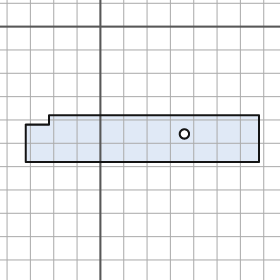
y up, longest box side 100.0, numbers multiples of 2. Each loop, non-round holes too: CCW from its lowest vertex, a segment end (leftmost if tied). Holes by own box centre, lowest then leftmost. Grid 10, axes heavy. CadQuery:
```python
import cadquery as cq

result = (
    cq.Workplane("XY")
    .moveTo(-32.0, -58.0)
    .lineTo(68.0, -58.0)
    .lineTo(68.0, -38.0)
    .lineTo(-22.0, -38.0)
    .lineTo(-22.0, -42.0)
    .lineTo(-32.0, -42.0)
    .close()
    .moveTo(36.0, -46.0)
    .circle(2.0)
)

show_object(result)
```